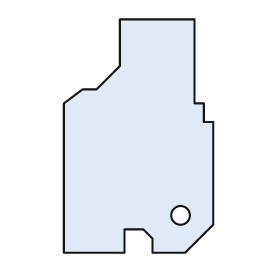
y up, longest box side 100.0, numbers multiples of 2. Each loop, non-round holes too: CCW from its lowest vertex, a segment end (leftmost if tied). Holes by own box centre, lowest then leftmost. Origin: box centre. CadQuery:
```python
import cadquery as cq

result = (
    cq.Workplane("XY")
    .moveTo(-32.0, -50.0)
    .lineTo(-6.0, -50.0)
    .lineTo(-6.0, -40.0)
    .lineTo(2.0, -40.0)
    .lineTo(6.0, -44.0)
    .lineTo(6.0, -50.0)
    .lineTo(20.0, -50.0)
    .lineTo(32.0, -38.0)
    .lineTo(32.0, 6.0)
    .lineTo(28.0, 6.0)
    .lineTo(28.0, 14.0)
    .lineTo(24.0, 14.0)
    .lineTo(24.0, 50.0)
    .lineTo(-8.0, 50.0)
    .lineTo(-8.0, 30.0)
    .lineTo(-18.0, 20.0)
    .lineTo(-24.0, 20.0)
    .lineTo(-32.0, 14.0)
    .close()
    .moveTo(18.0, -34.0)
    .circle(4.0)
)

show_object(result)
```